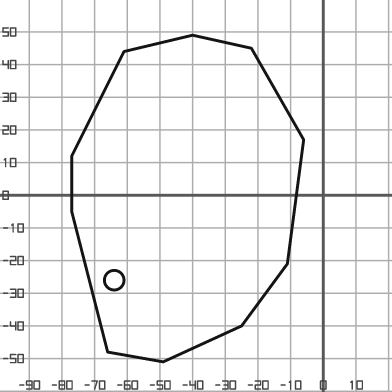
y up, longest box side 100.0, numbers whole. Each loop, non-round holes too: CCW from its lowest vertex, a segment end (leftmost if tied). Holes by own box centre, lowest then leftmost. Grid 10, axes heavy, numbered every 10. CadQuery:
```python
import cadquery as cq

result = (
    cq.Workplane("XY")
    .moveTo(-49.0, -51.0)
    .lineTo(-25.0, -40.0)
    .lineTo(-11.0, -21.0)
    .lineTo(-6.0, 17.0)
    .lineTo(-22.0, 45.0)
    .lineTo(-40.0, 49.0)
    .lineTo(-61.0, 44.0)
    .lineTo(-77.0, 12.0)
    .lineTo(-77.0, -5.0)
    .lineTo(-66.0, -48.0)
    .close()
    .moveTo(-64.0, -26.0)
    .circle(3.0)
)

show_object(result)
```